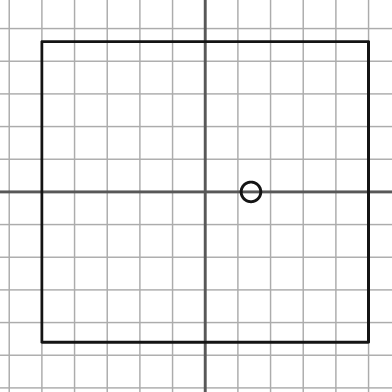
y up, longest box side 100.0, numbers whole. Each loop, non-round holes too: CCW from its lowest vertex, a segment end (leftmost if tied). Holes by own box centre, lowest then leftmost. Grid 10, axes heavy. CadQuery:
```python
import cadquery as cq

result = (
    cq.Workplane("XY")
    .moveTo(-50.0, -46.0)
    .lineTo(50.0, -46.0)
    .lineTo(50.0, 46.0)
    .lineTo(-50.0, 46.0)
    .close()
    .moveTo(14.0, 0.0)
    .circle(3.0)
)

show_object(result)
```